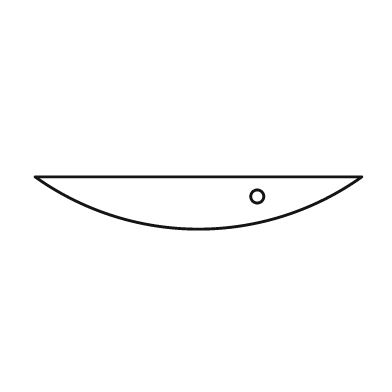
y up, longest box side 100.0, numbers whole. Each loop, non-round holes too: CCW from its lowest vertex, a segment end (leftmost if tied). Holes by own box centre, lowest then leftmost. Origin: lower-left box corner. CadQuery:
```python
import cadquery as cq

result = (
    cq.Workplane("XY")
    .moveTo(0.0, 16.0)
    .threePointArc((50.0, 0.0), (100.0, 16.0))
    .close()
    .moveTo(68.0, 10.0)
    .circle(2.0)
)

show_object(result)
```